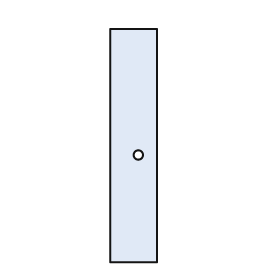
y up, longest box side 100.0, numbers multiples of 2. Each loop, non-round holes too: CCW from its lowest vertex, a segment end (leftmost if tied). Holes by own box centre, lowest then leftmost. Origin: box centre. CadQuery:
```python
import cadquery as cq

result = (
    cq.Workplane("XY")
    .moveTo(-10.0, -50.0)
    .lineTo(10.0, -50.0)
    .lineTo(10.0, 50.0)
    .lineTo(-10.0, 50.0)
    .close()
    .moveTo(2.0, -4.0)
    .circle(2.0)
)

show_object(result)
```